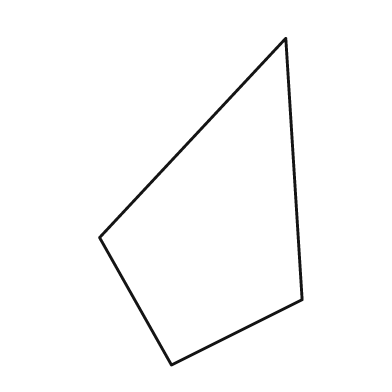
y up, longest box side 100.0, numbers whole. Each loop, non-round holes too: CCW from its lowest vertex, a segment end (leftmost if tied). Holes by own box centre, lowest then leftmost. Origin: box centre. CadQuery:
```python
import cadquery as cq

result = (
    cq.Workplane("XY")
    .moveTo(-9.0, -50.0)
    .lineTo(31.0, -30.0)
    .lineTo(26.0, 50.0)
    .lineTo(-31.0, -11.0)
    .close()
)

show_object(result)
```